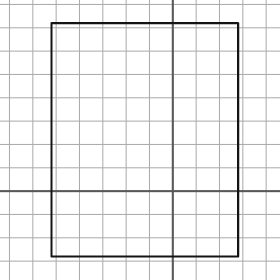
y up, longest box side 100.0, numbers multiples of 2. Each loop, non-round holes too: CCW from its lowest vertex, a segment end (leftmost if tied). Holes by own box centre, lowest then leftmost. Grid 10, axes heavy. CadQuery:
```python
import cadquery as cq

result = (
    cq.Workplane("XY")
    .moveTo(-52.0, -28.0)
    .lineTo(28.0, -28.0)
    .lineTo(28.0, 72.0)
    .lineTo(-52.0, 72.0)
    .close()
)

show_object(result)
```